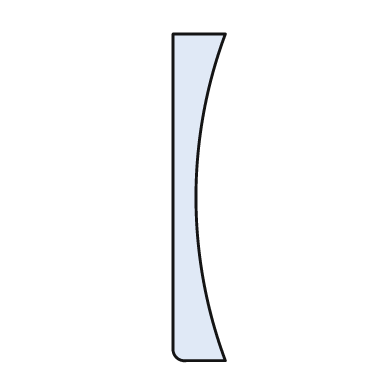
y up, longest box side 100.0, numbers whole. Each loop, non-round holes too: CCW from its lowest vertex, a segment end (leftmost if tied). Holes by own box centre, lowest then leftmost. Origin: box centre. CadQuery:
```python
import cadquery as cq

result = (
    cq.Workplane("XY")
    .moveTo(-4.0, -50.0)
    .lineTo(8.0, -50.0)
    .threePointArc((-1.0, 0.0), (8.0, 50.0))
    .lineTo(-8.0, 50.0)
    .lineTo(-8.0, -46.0)
    .threePointArc((-7.0, -49.0), (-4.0, -50.0))
    .close()
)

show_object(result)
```